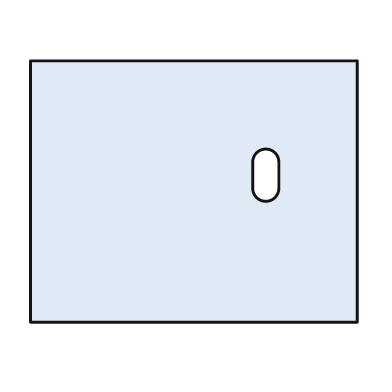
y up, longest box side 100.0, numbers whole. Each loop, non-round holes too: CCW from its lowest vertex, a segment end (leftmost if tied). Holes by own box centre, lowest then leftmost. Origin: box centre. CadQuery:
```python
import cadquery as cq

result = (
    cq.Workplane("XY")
    .moveTo(-50.0, -40.0)
    .lineTo(50.0, -40.0)
    .lineTo(50.0, 40.0)
    .lineTo(-50.0, 40.0)
    .close()
    .moveTo(18.0, 1.0)
    .threePointArc((22.0, -3.0), (26.0, 1.0))
    .lineTo(26.0, 9.0)
    .threePointArc((22.0, 13.0), (18.0, 9.0))
    .close()
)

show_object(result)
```